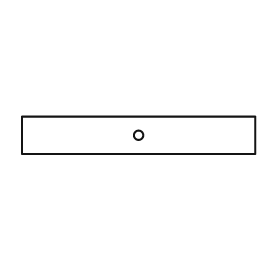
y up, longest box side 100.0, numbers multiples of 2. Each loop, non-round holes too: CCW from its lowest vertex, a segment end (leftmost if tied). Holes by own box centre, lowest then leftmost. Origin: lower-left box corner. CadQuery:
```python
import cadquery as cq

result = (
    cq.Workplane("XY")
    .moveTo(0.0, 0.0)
    .lineTo(100.0, 0.0)
    .lineTo(100.0, 16.0)
    .lineTo(0.0, 16.0)
    .close()
    .moveTo(50.0, 8.0)
    .circle(2.0)
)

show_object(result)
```